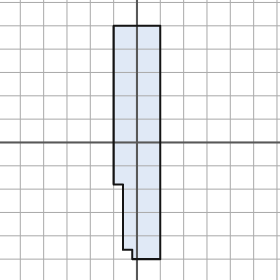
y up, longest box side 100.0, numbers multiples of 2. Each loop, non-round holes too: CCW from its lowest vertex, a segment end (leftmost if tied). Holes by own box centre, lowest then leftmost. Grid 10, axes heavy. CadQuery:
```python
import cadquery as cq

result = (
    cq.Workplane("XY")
    .moveTo(-2.0, -50.0)
    .lineTo(10.0, -50.0)
    .lineTo(10.0, 50.0)
    .lineTo(-10.0, 50.0)
    .lineTo(-10.0, -18.0)
    .lineTo(-6.0, -18.0)
    .lineTo(-6.0, -46.0)
    .lineTo(-2.0, -46.0)
    .close()
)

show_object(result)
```